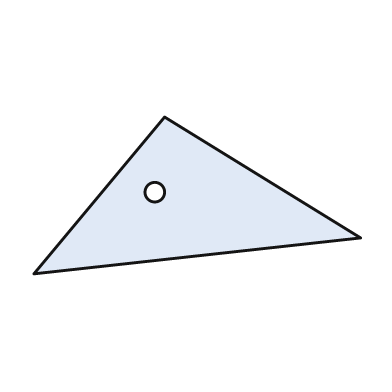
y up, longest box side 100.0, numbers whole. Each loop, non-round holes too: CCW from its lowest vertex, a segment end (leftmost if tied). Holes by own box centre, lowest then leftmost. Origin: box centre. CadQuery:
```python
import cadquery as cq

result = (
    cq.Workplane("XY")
    .moveTo(-50.0, -24.0)
    .lineTo(50.0, -13.0)
    .lineTo(-10.0, 24.0)
    .close()
    .moveTo(-13.0, 1.0)
    .circle(3.0)
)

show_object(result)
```